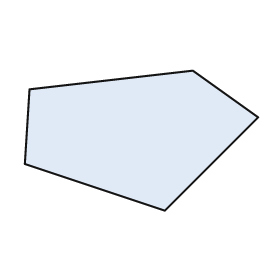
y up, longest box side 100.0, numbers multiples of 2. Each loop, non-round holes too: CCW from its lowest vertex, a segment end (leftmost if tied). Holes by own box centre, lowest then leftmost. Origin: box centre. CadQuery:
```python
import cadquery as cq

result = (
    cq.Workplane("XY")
    .moveTo(10.0, -30.0)
    .lineTo(50.0, 10.0)
    .lineTo(22.0, 30.0)
    .lineTo(-48.0, 22.0)
    .lineTo(-50.0, -10.0)
    .close()
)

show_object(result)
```